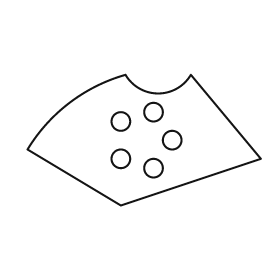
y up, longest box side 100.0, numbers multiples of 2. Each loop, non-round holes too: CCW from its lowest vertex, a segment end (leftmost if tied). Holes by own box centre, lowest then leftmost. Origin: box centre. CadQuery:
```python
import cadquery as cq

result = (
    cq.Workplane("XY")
    .moveTo(-10.0, -28.0)
    .lineTo(50.0, -8.0)
    .lineTo(20.0, 28.0)
    .threePointArc((6.0, 20.0), (-8.0, 28.0))
    .threePointArc((-32.0, 16.0), (-50.0, -4.0))
    .close()
    .moveTo(4.0, -12.0)
    .circle(4.0)
    .moveTo(-10.0, -8.0)
    .circle(4.0)
    .moveTo(12.0, 0.0)
    .circle(4.0)
    .moveTo(-10.0, 8.0)
    .circle(4.0)
    .moveTo(4.0, 12.0)
    .circle(4.0)
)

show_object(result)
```